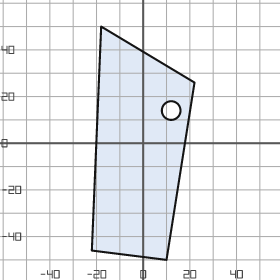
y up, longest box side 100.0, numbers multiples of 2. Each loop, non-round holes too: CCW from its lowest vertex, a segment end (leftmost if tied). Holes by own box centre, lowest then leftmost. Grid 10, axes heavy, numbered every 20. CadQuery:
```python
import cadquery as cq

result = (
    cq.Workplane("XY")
    .moveTo(10.0, -50.0)
    .lineTo(22.0, 26.0)
    .lineTo(-18.0, 50.0)
    .lineTo(-22.0, -46.0)
    .close()
    .moveTo(12.0, 14.0)
    .circle(4.0)
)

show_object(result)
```